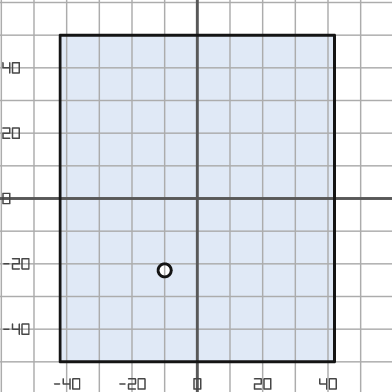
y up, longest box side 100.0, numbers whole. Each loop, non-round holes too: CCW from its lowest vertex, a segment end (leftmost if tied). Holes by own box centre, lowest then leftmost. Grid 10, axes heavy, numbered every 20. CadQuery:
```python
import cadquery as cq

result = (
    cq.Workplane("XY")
    .moveTo(-42.0, -50.0)
    .lineTo(42.0, -50.0)
    .lineTo(42.0, 50.0)
    .lineTo(-42.0, 50.0)
    .close()
    .moveTo(-10.0, -22.0)
    .circle(2.0)
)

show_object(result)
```